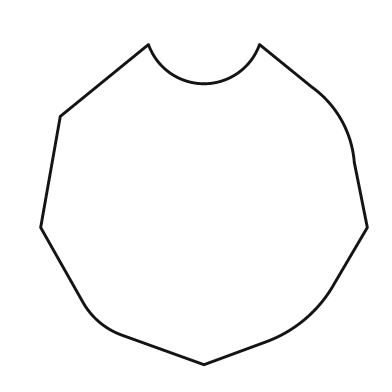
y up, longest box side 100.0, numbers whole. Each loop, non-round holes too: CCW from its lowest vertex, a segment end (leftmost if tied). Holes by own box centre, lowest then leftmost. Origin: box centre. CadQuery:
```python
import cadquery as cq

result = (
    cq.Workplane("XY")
    .moveTo(0.0, -49.0)
    .lineTo(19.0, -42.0)
    .threePointArc((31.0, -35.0), (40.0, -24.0))
    .lineTo(50.0, -7.0)
    .lineTo(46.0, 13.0)
    .threePointArc((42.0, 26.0), (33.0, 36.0))
    .lineTo(17.0, 49.0)
    .threePointArc((0.0, 37.0), (-17.0, 49.0))
    .lineTo(-44.0, 27.0)
    .lineTo(-50.0, -7.0)
    .lineTo(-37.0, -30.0)
    .threePointArc((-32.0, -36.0), (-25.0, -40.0))
    .close()
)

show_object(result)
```